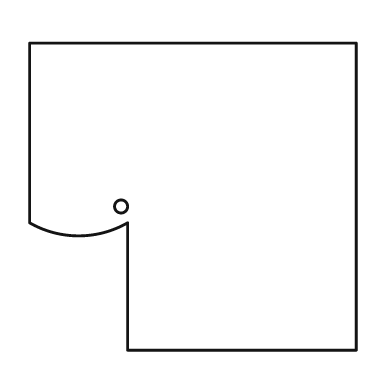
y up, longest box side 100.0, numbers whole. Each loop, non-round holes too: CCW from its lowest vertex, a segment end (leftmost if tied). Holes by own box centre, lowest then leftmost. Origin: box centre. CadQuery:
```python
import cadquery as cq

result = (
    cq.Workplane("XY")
    .moveTo(-20.0, -47.0)
    .lineTo(50.0, -47.0)
    .lineTo(50.0, 47.0)
    .lineTo(-50.0, 47.0)
    .lineTo(-50.0, -8.0)
    .threePointArc((-35.0, -12.0), (-20.0, -8.0))
    .close()
    .moveTo(-22.0, -3.0)
    .circle(2.0)
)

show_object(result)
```